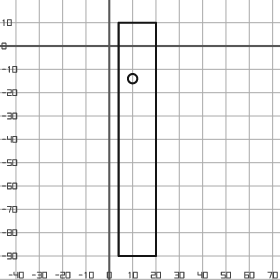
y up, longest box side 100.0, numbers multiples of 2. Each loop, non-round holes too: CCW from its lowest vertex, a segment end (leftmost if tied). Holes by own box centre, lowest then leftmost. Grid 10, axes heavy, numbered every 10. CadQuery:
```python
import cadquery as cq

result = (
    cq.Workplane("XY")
    .moveTo(4.0, -90.0)
    .lineTo(20.0, -90.0)
    .lineTo(20.0, 10.0)
    .lineTo(4.0, 10.0)
    .close()
    .moveTo(10.0, -14.0)
    .circle(2.0)
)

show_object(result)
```